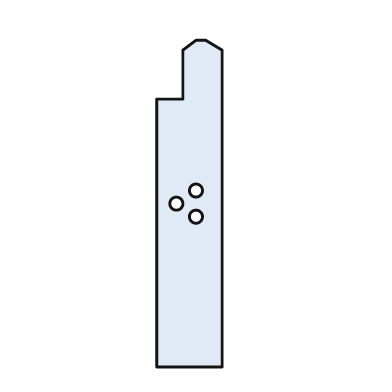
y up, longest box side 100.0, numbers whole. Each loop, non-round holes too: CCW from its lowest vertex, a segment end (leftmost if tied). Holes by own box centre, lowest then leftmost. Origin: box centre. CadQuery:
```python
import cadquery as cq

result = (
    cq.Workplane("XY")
    .moveTo(-10.0, -50.0)
    .lineTo(10.0, -50.0)
    .lineTo(10.0, 47.0)
    .lineTo(5.0, 50.0)
    .lineTo(2.0, 50.0)
    .lineTo(-2.0, 47.0)
    .lineTo(-2.0, 32.0)
    .lineTo(-10.0, 32.0)
    .close()
    .moveTo(2.0, -4.0)
    .circle(2.0)
    .moveTo(-4.0, 0.0)
    .circle(2.0)
    .moveTo(2.0, 4.0)
    .circle(2.0)
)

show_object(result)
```